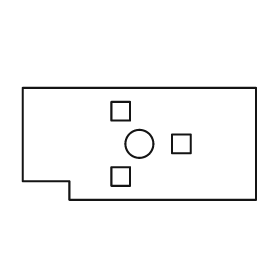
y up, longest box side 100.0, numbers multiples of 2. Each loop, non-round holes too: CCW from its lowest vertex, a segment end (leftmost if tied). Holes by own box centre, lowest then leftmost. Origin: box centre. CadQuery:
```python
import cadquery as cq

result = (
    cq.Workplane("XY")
    .moveTo(-30.0, -24.0)
    .lineTo(50.0, -24.0)
    .lineTo(50.0, 24.0)
    .lineTo(-50.0, 24.0)
    .lineTo(-50.0, -16.0)
    .lineTo(-30.0, -16.0)
    .close()
    .moveTo(-12.0, -18.0)
    .lineTo(-4.0, -18.0)
    .lineTo(-4.0, -10.0)
    .lineTo(-12.0, -10.0)
    .close()
    .moveTo(0.0, 0.0)
    .circle(6.0)
    .moveTo(14.0, -4.0)
    .lineTo(22.0, -4.0)
    .lineTo(22.0, 4.0)
    .lineTo(14.0, 4.0)
    .close()
    .moveTo(-12.0, 10.0)
    .lineTo(-4.0, 10.0)
    .lineTo(-4.0, 18.0)
    .lineTo(-12.0, 18.0)
    .close()
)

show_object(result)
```